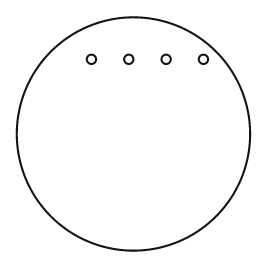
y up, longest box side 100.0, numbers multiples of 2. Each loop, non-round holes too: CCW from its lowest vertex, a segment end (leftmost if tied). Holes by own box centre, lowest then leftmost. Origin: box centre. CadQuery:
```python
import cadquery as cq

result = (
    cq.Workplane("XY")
    .moveTo(0.0, 0.0)
    .circle(50.0)
    .moveTo(-18.0, 32.0)
    .circle(2.0)
    .moveTo(-2.0, 32.0)
    .circle(2.0)
    .moveTo(14.0, 32.0)
    .circle(2.0)
    .moveTo(30.0, 32.0)
    .circle(2.0)
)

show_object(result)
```